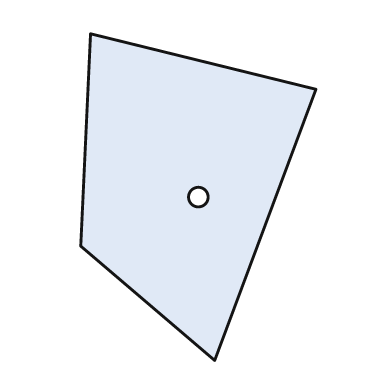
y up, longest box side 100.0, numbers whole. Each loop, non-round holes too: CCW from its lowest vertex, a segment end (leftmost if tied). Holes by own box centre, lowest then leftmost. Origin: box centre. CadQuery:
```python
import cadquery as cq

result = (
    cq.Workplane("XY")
    .moveTo(5.0, -50.0)
    .lineTo(36.0, 33.0)
    .lineTo(-33.0, 50.0)
    .lineTo(-36.0, -15.0)
    .close()
    .moveTo(0.0, 0.0)
    .circle(3.0)
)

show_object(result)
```